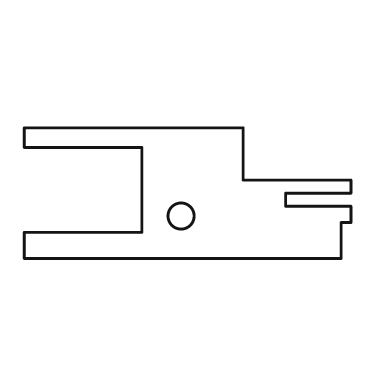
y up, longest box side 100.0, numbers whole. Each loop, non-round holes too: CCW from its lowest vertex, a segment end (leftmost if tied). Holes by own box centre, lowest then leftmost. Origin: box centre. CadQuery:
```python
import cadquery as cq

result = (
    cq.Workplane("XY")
    .moveTo(-50.0, -20.0)
    .lineTo(47.0, -20.0)
    .lineTo(47.0, -9.0)
    .lineTo(50.0, -9.0)
    .lineTo(50.0, -4.0)
    .lineTo(30.0, -4.0)
    .lineTo(30.0, 0.0)
    .lineTo(50.0, 0.0)
    .lineTo(50.0, 4.0)
    .lineTo(17.0, 4.0)
    .lineTo(17.0, 20.0)
    .lineTo(-50.0, 20.0)
    .lineTo(-50.0, 14.0)
    .lineTo(-14.0, 14.0)
    .lineTo(-14.0, -12.0)
    .lineTo(-50.0, -12.0)
    .close()
    .moveTo(-2.0, -7.0)
    .circle(4.0)
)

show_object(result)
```